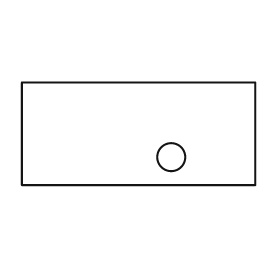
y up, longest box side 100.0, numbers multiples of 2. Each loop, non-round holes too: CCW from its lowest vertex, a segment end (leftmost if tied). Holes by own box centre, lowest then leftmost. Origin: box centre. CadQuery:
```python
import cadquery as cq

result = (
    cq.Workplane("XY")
    .moveTo(-50.0, -22.0)
    .lineTo(50.0, -22.0)
    .lineTo(50.0, 22.0)
    .lineTo(-50.0, 22.0)
    .close()
    .moveTo(14.0, -10.0)
    .circle(6.0)
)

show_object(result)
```